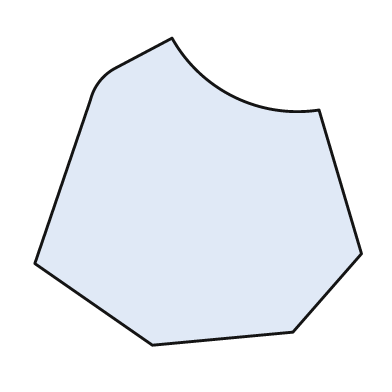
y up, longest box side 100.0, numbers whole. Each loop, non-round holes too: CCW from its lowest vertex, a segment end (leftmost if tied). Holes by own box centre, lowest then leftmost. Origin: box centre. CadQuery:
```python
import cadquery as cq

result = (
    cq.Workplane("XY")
    .moveTo(-14.0, -47.0)
    .lineTo(29.0, -43.0)
    .lineTo(50.0, -19.0)
    .lineTo(37.0, 25.0)
    .threePointArc((11.0, 29.0), (-8.0, 47.0))
    .lineTo(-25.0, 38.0)
    .threePointArc((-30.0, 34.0), (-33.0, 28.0))
    .lineTo(-50.0, -22.0)
    .close()
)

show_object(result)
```